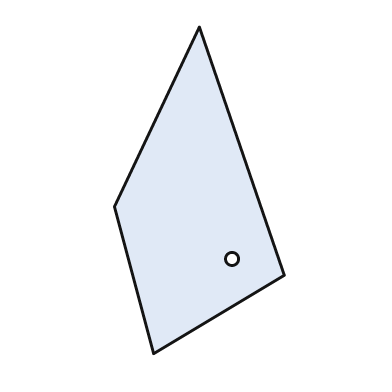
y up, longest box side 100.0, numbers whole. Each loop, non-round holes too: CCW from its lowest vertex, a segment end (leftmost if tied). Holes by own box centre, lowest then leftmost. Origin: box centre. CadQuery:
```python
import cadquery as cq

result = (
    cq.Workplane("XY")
    .moveTo(-14.0, -50.0)
    .lineTo(26.0, -26.0)
    .lineTo(0.0, 50.0)
    .lineTo(-26.0, -5.0)
    .close()
    .moveTo(10.0, -21.0)
    .circle(2.0)
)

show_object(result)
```